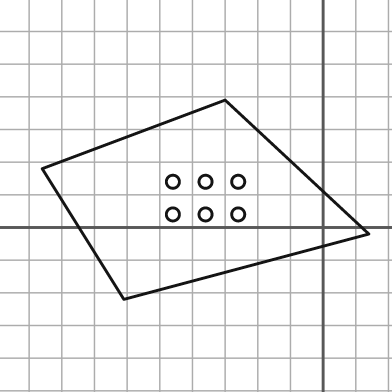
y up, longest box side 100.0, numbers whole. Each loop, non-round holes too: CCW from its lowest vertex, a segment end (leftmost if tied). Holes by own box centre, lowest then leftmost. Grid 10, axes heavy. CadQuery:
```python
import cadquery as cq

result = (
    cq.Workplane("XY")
    .moveTo(-61.0, -22.0)
    .lineTo(14.0, -2.0)
    .lineTo(-30.0, 39.0)
    .lineTo(-86.0, 18.0)
    .close()
    .moveTo(-46.0, 4.0)
    .circle(2.0)
    .moveTo(-36.0, 4.0)
    .circle(2.0)
    .moveTo(-26.0, 4.0)
    .circle(2.0)
    .moveTo(-46.0, 14.0)
    .circle(2.0)
    .moveTo(-36.0, 14.0)
    .circle(2.0)
    .moveTo(-26.0, 14.0)
    .circle(2.0)
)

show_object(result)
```